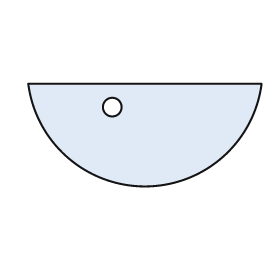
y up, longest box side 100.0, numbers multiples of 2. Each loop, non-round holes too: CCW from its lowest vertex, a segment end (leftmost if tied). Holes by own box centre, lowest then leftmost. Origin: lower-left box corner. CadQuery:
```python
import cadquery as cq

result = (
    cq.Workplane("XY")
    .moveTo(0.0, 44.0)
    .threePointArc((50.0, 0.0), (100.0, 44.0))
    .close()
    .moveTo(36.0, 34.0)
    .circle(4.0)
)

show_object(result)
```